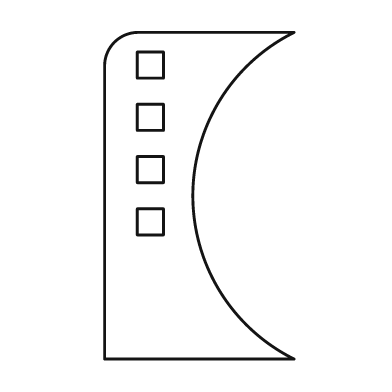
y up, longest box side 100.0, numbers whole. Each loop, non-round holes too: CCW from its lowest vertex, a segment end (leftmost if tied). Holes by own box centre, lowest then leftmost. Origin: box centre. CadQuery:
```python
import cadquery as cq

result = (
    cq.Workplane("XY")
    .moveTo(-29.0, -50.0)
    .lineTo(29.0, -50.0)
    .threePointArc((-2.0, 0.0), (29.0, 50.0))
    .lineTo(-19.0, 50.0)
    .threePointArc((-26.0, 47.0), (-29.0, 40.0))
    .close()
    .moveTo(-19.0, -12.0)
    .lineTo(-11.0, -12.0)
    .lineTo(-11.0, -4.0)
    .lineTo(-19.0, -4.0)
    .close()
    .moveTo(-19.0, 4.0)
    .lineTo(-11.0, 4.0)
    .lineTo(-11.0, 12.0)
    .lineTo(-19.0, 12.0)
    .close()
    .moveTo(-19.0, 20.0)
    .lineTo(-11.0, 20.0)
    .lineTo(-11.0, 28.0)
    .lineTo(-19.0, 28.0)
    .close()
    .moveTo(-19.0, 36.0)
    .lineTo(-11.0, 36.0)
    .lineTo(-11.0, 44.0)
    .lineTo(-19.0, 44.0)
    .close()
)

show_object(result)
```